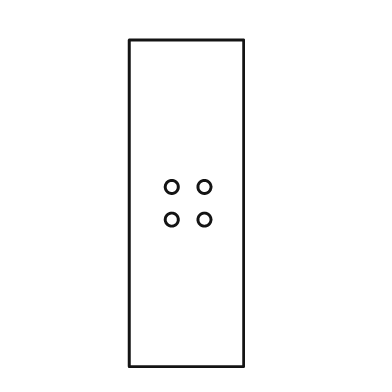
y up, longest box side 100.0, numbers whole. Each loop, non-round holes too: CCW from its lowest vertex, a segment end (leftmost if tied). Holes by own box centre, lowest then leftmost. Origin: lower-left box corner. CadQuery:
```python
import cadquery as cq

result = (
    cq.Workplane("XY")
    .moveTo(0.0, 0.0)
    .lineTo(35.0, 0.0)
    .lineTo(35.0, 100.0)
    .lineTo(0.0, 100.0)
    .close()
    .moveTo(13.0, 45.0)
    .circle(2.0)
    .moveTo(23.0, 45.0)
    .circle(2.0)
    .moveTo(13.0, 55.0)
    .circle(2.0)
    .moveTo(23.0, 55.0)
    .circle(2.0)
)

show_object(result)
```